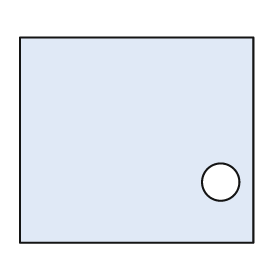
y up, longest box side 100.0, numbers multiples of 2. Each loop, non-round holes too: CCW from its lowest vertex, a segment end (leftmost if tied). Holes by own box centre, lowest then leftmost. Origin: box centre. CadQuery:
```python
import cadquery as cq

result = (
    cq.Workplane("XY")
    .moveTo(-50.0, -44.0)
    .lineTo(50.0, -44.0)
    .lineTo(50.0, 44.0)
    .lineTo(-50.0, 44.0)
    .close()
    .moveTo(36.0, -18.0)
    .circle(8.0)
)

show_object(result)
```